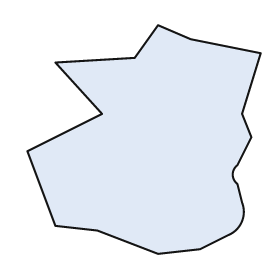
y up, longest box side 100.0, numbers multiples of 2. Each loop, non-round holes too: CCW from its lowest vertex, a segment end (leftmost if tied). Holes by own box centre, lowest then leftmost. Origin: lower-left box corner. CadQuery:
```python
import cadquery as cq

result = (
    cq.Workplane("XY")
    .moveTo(56.0, 0.0)
    .lineTo(74.0, 2.0)
    .lineTo(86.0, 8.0)
    .threePointArc((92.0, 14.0), (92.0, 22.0))
    .lineTo(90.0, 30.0)
    .threePointArc((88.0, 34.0), (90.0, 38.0))
    .lineTo(96.0, 50.0)
    .lineTo(92.0, 60.0)
    .lineTo(100.0, 86.0)
    .lineTo(70.0, 92.0)
    .lineTo(56.0, 98.0)
    .lineTo(46.0, 84.0)
    .lineTo(12.0, 82.0)
    .lineTo(32.0, 60.0)
    .lineTo(0.0, 44.0)
    .lineTo(12.0, 12.0)
    .lineTo(30.0, 10.0)
    .close()
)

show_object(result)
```